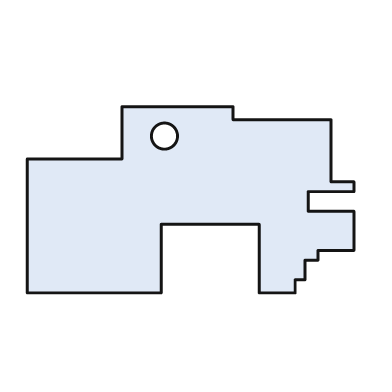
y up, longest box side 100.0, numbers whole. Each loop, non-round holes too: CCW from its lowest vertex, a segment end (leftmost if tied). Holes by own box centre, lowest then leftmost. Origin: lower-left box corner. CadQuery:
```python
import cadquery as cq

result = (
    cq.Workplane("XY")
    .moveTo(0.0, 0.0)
    .lineTo(41.0, 0.0)
    .lineTo(41.0, 21.0)
    .lineTo(71.0, 21.0)
    .lineTo(71.0, 0.0)
    .lineTo(82.0, 0.0)
    .lineTo(82.0, 4.0)
    .lineTo(85.0, 4.0)
    .lineTo(85.0, 10.0)
    .lineTo(89.0, 10.0)
    .lineTo(89.0, 13.0)
    .lineTo(100.0, 13.0)
    .lineTo(100.0, 25.0)
    .lineTo(86.0, 25.0)
    .lineTo(86.0, 31.0)
    .lineTo(100.0, 31.0)
    .lineTo(100.0, 34.0)
    .lineTo(93.0, 34.0)
    .lineTo(93.0, 53.0)
    .lineTo(63.0, 53.0)
    .lineTo(63.0, 57.0)
    .lineTo(29.0, 57.0)
    .lineTo(29.0, 41.0)
    .lineTo(0.0, 41.0)
    .close()
    .moveTo(42.0, 48.0)
    .circle(4.0)
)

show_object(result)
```